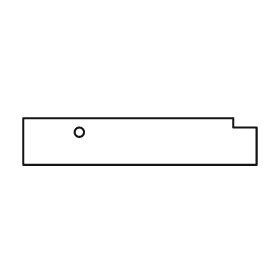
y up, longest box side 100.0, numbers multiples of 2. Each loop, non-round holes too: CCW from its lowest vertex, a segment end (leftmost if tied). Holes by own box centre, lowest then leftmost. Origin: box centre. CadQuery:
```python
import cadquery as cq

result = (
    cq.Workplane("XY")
    .moveTo(-50.0, -10.0)
    .lineTo(50.0, -10.0)
    .lineTo(50.0, 6.0)
    .lineTo(40.0, 6.0)
    .lineTo(40.0, 10.0)
    .lineTo(-50.0, 10.0)
    .close()
    .moveTo(-26.0, 4.0)
    .circle(2.0)
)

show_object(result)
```